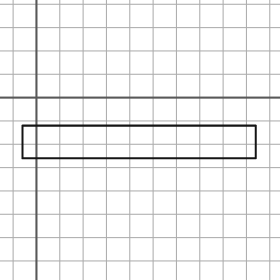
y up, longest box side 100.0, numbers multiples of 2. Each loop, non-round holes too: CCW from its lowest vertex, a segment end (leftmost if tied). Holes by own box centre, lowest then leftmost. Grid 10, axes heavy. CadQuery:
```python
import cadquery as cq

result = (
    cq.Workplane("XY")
    .moveTo(-6.0, -26.0)
    .lineTo(94.0, -26.0)
    .lineTo(94.0, -12.0)
    .lineTo(-6.0, -12.0)
    .close()
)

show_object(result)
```